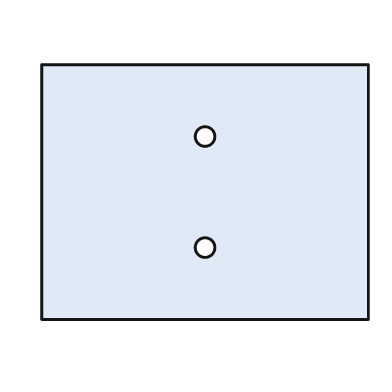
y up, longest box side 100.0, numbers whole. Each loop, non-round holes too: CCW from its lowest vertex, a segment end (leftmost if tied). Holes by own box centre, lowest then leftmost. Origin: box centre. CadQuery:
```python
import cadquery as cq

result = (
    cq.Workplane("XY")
    .moveTo(-50.0, -39.0)
    .lineTo(50.0, -39.0)
    .lineTo(50.0, 39.0)
    .lineTo(-50.0, 39.0)
    .close()
    .moveTo(0.0, -17.0)
    .circle(3.0)
    .moveTo(0.0, 17.0)
    .circle(3.0)
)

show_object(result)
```